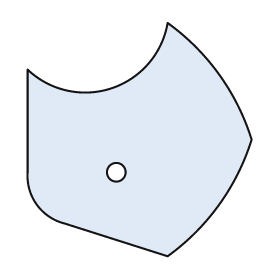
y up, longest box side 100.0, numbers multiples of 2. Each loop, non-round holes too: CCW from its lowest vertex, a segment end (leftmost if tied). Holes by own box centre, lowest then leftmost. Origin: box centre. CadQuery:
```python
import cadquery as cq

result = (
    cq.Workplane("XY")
    .moveTo(12.0, -50.0)
    .threePointArc((34.0, -28.0), (48.0, 0.0))
    .threePointArc((34.0, 28.0), (12.0, 50.0))
    .threePointArc((-12.0, 22.0), (-48.0, 30.0))
    .lineTo(-48.0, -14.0)
    .threePointArc((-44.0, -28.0), (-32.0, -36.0))
    .close()
    .moveTo(-10.0, -14.0)
    .circle(4.0)
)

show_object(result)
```